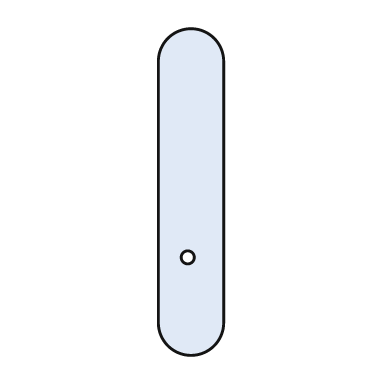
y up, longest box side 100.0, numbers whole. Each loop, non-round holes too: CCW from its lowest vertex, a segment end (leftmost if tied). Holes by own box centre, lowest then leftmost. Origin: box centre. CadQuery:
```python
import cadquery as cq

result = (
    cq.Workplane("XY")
    .moveTo(-10.0, -40.0)
    .threePointArc((0.0, -50.0), (10.0, -40.0))
    .lineTo(10.0, 40.0)
    .threePointArc((0.0, 50.0), (-10.0, 40.0))
    .close()
    .moveTo(-1.0, -20.0)
    .circle(2.0)
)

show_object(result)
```